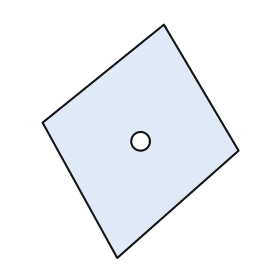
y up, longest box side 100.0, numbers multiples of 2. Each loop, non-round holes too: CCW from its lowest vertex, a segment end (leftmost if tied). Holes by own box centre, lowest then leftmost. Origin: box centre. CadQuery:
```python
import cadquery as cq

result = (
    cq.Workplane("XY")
    .moveTo(-10.0, -50.0)
    .lineTo(42.0, -4.0)
    .lineTo(10.0, 50.0)
    .lineTo(-42.0, 8.0)
    .close()
    .moveTo(0.0, 0.0)
    .circle(4.0)
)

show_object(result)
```